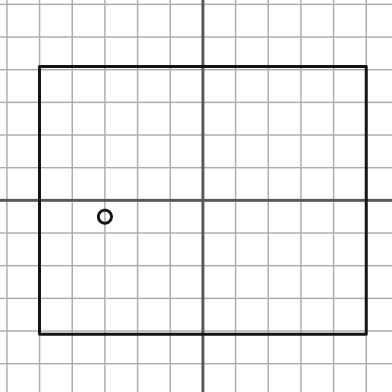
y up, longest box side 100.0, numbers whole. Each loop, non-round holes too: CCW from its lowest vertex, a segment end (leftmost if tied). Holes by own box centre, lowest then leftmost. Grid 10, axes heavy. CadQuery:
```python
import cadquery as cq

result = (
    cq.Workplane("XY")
    .moveTo(-50.0, -41.0)
    .lineTo(50.0, -41.0)
    .lineTo(50.0, 41.0)
    .lineTo(-50.0, 41.0)
    .close()
    .moveTo(-30.0, -5.0)
    .circle(2.0)
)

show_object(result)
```